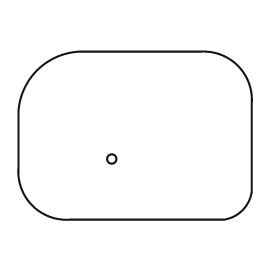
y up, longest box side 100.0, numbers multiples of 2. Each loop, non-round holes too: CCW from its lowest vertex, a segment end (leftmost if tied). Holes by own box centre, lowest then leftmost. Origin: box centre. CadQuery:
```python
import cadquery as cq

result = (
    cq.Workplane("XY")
    .moveTo(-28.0, -36.0)
    .lineTo(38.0, -36.0)
    .threePointArc((46.0, -32.0), (50.0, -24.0))
    .lineTo(50.0, 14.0)
    .threePointArc((44.0, 30.0), (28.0, 36.0))
    .lineTo(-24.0, 36.0)
    .threePointArc((-42.0, 28.0), (-50.0, 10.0))
    .lineTo(-50.0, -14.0)
    .threePointArc((-44.0, -30.0), (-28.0, -36.0))
    .close()
    .moveTo(-10.0, -10.0)
    .circle(2.0)
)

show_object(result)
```